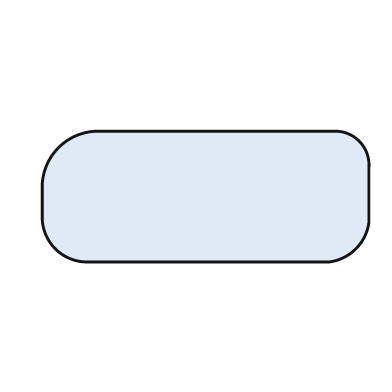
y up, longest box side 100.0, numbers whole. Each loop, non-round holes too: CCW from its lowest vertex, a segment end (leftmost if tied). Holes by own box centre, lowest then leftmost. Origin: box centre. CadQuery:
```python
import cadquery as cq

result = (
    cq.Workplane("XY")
    .moveTo(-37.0, -20.0)
    .lineTo(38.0, -20.0)
    .threePointArc((46.0, -16.0), (50.0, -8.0))
    .lineTo(50.0, 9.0)
    .threePointArc((47.0, 17.0), (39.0, 20.0))
    .lineTo(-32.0, 20.0)
    .threePointArc((-45.0, 15.0), (-50.0, 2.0))
    .lineTo(-50.0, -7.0)
    .threePointArc((-46.0, -16.0), (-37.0, -20.0))
    .close()
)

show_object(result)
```